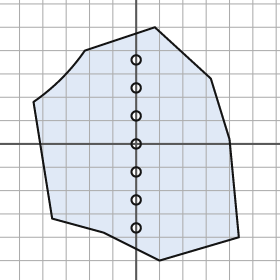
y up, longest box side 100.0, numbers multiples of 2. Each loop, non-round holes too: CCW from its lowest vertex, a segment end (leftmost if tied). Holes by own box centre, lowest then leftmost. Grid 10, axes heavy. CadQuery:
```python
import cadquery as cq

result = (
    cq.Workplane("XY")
    .moveTo(10.0, -50.0)
    .lineTo(44.0, -40.0)
    .lineTo(40.0, 2.0)
    .lineTo(32.0, 28.0)
    .lineTo(8.0, 50.0)
    .lineTo(-22.0, 40.0)
    .threePointArc((-32.0, 28.0), (-44.0, 18.0))
    .lineTo(-36.0, -32.0)
    .lineTo(-14.0, -38.0)
    .close()
    .moveTo(0.0, -36.0)
    .circle(2.0)
    .moveTo(0.0, -24.0)
    .circle(2.0)
    .moveTo(0.0, -12.0)
    .circle(2.0)
    .moveTo(0.0, 0.0)
    .circle(2.0)
    .moveTo(0.0, 12.0)
    .circle(2.0)
    .moveTo(0.0, 24.0)
    .circle(2.0)
    .moveTo(0.0, 36.0)
    .circle(2.0)
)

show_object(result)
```